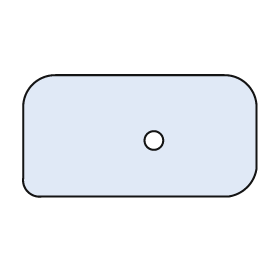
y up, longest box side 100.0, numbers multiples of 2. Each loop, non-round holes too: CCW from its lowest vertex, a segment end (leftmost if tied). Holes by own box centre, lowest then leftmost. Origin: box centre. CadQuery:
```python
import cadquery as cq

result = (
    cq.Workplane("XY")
    .moveTo(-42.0, -26.0)
    .lineTo(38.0, -26.0)
    .threePointArc((46.0, -22.0), (50.0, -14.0))
    .lineTo(50.0, 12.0)
    .threePointArc((46.0, 22.0), (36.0, 26.0))
    .lineTo(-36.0, 26.0)
    .threePointArc((-46.0, 22.0), (-50.0, 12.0))
    .lineTo(-50.0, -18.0)
    .threePointArc((-48.0, -24.0), (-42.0, -26.0))
    .close()
    .moveTo(6.0, -2.0)
    .circle(4.0)
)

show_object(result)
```